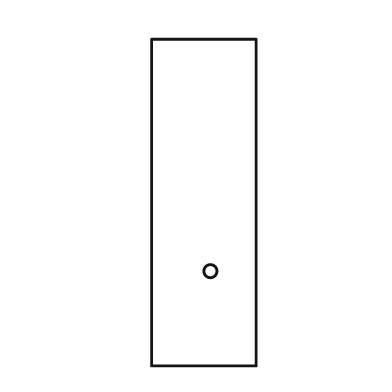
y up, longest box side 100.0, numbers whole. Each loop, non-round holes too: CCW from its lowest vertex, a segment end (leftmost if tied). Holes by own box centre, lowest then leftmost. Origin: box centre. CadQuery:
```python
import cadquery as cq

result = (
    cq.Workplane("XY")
    .moveTo(-16.0, -50.0)
    .lineTo(16.0, -50.0)
    .lineTo(16.0, 50.0)
    .lineTo(-16.0, 50.0)
    .close()
    .moveTo(2.0, -21.0)
    .circle(2.0)
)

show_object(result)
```